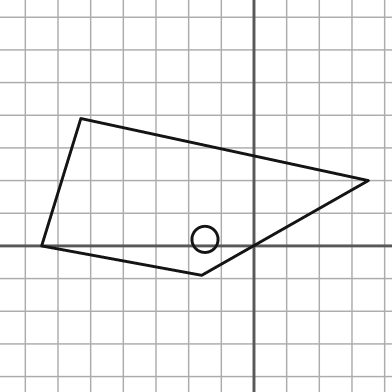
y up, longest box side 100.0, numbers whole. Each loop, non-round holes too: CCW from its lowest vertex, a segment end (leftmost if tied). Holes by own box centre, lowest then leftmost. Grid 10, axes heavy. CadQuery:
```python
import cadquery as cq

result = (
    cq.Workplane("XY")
    .moveTo(-16.0, -9.0)
    .lineTo(35.0, 20.0)
    .lineTo(-53.0, 39.0)
    .lineTo(-65.0, 0.0)
    .close()
    .moveTo(-15.0, 2.0)
    .circle(4.0)
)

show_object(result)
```